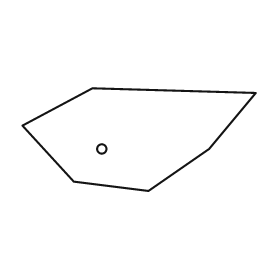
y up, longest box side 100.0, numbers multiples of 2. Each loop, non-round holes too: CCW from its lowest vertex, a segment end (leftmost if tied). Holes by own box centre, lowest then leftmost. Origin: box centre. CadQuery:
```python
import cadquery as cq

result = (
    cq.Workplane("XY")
    .moveTo(4.0, -22.0)
    .lineTo(30.0, -4.0)
    .lineTo(50.0, 20.0)
    .lineTo(-20.0, 22.0)
    .lineTo(-50.0, 6.0)
    .lineTo(-28.0, -18.0)
    .close()
    .moveTo(-16.0, -4.0)
    .circle(2.0)
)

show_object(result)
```